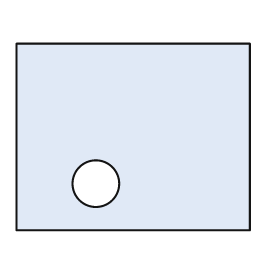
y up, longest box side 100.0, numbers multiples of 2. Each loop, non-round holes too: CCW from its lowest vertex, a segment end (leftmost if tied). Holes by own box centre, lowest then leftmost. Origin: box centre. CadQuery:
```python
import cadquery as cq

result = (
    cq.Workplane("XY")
    .moveTo(-50.0, -40.0)
    .lineTo(50.0, -40.0)
    .lineTo(50.0, 40.0)
    .lineTo(-50.0, 40.0)
    .close()
    .moveTo(-16.0, -20.0)
    .circle(10.0)
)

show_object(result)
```